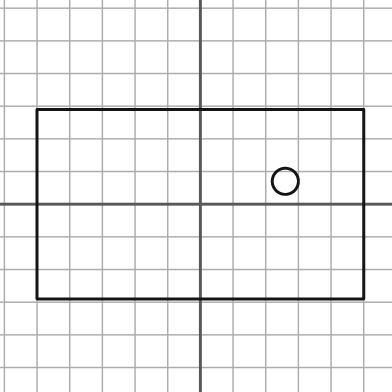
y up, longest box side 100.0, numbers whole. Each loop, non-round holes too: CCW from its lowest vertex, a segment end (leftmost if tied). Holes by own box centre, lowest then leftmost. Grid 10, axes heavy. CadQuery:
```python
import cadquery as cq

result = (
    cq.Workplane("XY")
    .moveTo(-50.0, -29.0)
    .lineTo(50.0, -29.0)
    .lineTo(50.0, 29.0)
    .lineTo(-50.0, 29.0)
    .close()
    .moveTo(26.0, 7.0)
    .circle(4.0)
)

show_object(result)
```